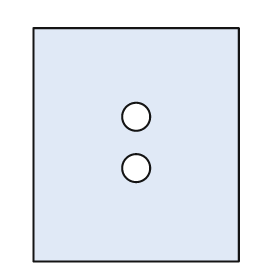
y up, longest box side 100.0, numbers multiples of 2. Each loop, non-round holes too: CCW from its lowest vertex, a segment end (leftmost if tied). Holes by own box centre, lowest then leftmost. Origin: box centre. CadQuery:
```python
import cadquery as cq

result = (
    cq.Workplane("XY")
    .moveTo(-44.0, -50.0)
    .lineTo(44.0, -50.0)
    .lineTo(44.0, 50.0)
    .lineTo(-44.0, 50.0)
    .close()
    .moveTo(0.0, -10.0)
    .circle(6.0)
    .moveTo(0.0, 12.0)
    .circle(6.0)
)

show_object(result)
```